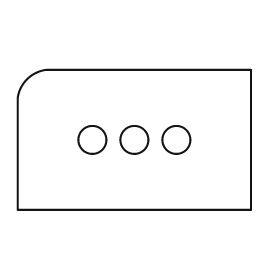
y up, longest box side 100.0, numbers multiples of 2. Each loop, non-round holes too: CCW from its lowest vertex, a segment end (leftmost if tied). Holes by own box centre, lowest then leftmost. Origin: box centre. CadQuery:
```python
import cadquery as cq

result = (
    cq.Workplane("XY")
    .moveTo(-50.0, -30.0)
    .lineTo(50.0, -30.0)
    .lineTo(50.0, 30.0)
    .lineTo(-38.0, 30.0)
    .threePointArc((-46.0, 26.0), (-50.0, 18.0))
    .close()
    .moveTo(-18.0, 0.0)
    .circle(6.0)
    .moveTo(0.0, 0.0)
    .circle(6.0)
    .moveTo(18.0, 0.0)
    .circle(6.0)
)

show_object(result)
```